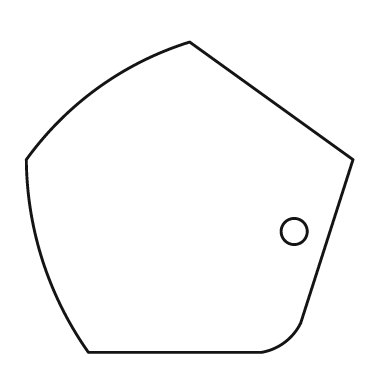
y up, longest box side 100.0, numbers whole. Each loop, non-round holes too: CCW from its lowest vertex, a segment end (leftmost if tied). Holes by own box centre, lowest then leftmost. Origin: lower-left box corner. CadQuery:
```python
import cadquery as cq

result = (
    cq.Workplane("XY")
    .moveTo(19.0, 0.0)
    .lineTo(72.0, 0.0)
    .threePointArc((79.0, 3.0), (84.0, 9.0))
    .lineTo(100.0, 59.0)
    .lineTo(50.0, 95.0)
    .threePointArc((22.0, 81.0), (0.0, 59.0))
    .threePointArc((5.0, 28.0), (19.0, 0.0))
    .close()
    .moveTo(82.0, 37.0)
    .circle(4.0)
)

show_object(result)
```